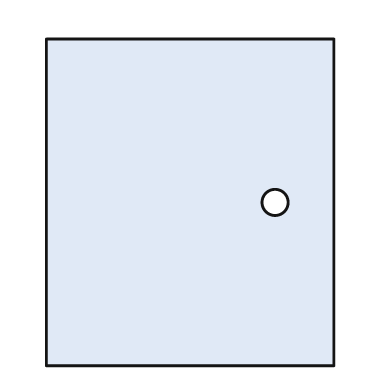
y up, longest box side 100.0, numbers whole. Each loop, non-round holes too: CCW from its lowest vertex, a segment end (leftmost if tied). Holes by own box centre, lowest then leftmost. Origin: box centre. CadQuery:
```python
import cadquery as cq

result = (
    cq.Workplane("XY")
    .moveTo(-44.0, -50.0)
    .lineTo(44.0, -50.0)
    .lineTo(44.0, 50.0)
    .lineTo(-44.0, 50.0)
    .close()
    .moveTo(26.0, 0.0)
    .circle(4.0)
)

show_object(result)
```